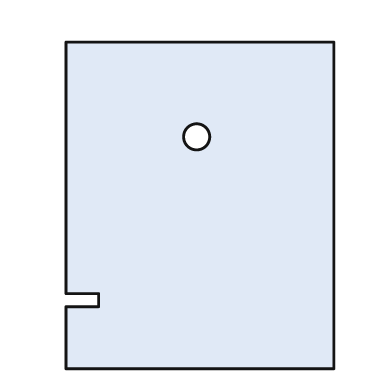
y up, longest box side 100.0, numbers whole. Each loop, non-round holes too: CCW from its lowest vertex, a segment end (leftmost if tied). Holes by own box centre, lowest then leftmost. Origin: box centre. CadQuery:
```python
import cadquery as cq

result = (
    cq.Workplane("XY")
    .moveTo(-41.0, -50.0)
    .lineTo(41.0, -50.0)
    .lineTo(41.0, 50.0)
    .lineTo(-41.0, 50.0)
    .lineTo(-41.0, -27.0)
    .lineTo(-31.0, -27.0)
    .lineTo(-31.0, -31.0)
    .lineTo(-41.0, -31.0)
    .close()
    .moveTo(-1.0, 21.0)
    .circle(4.0)
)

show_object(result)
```